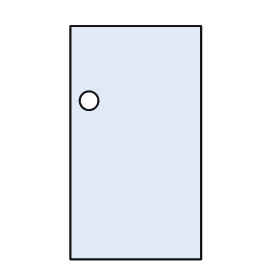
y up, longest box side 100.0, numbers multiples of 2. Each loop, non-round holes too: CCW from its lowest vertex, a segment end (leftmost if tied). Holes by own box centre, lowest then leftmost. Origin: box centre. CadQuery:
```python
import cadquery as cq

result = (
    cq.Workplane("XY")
    .moveTo(-28.0, -50.0)
    .lineTo(28.0, -50.0)
    .lineTo(28.0, 50.0)
    .lineTo(-28.0, 50.0)
    .close()
    .moveTo(-20.0, 18.0)
    .circle(4.0)
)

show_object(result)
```